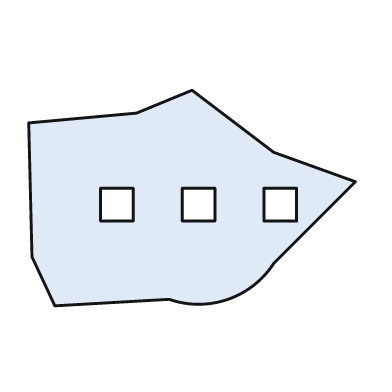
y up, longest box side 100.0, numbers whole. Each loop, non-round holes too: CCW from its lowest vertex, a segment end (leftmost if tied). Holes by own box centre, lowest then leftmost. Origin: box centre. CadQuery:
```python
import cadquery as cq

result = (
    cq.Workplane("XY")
    .moveTo(-42.0, -33.0)
    .lineTo(-7.0, -31.0)
    .threePointArc((11.0, -31.0), (25.0, -20.0))
    .lineTo(50.0, 5.0)
    .lineTo(25.0, 14.0)
    .lineTo(0.0, 33.0)
    .lineTo(-17.0, 26.0)
    .lineTo(-50.0, 23.0)
    .lineTo(-49.0, -18.0)
    .close()
    .moveTo(-28.0, -7.0)
    .lineTo(-18.0, -7.0)
    .lineTo(-18.0, 3.0)
    .lineTo(-28.0, 3.0)
    .close()
    .moveTo(-3.0, -7.0)
    .lineTo(7.0, -7.0)
    .lineTo(7.0, 3.0)
    .lineTo(-3.0, 3.0)
    .close()
    .moveTo(22.0, -7.0)
    .lineTo(32.0, -7.0)
    .lineTo(32.0, 3.0)
    .lineTo(22.0, 3.0)
    .close()
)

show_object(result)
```